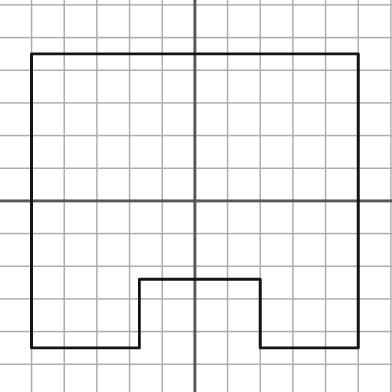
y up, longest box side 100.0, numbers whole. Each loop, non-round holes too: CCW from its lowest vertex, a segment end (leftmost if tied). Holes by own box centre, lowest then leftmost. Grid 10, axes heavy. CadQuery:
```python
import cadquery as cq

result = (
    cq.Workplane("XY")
    .moveTo(-50.0, -45.0)
    .lineTo(-17.0, -45.0)
    .lineTo(-17.0, -24.0)
    .lineTo(20.0, -24.0)
    .lineTo(20.0, -45.0)
    .lineTo(50.0, -45.0)
    .lineTo(50.0, 45.0)
    .lineTo(-50.0, 45.0)
    .close()
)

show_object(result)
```